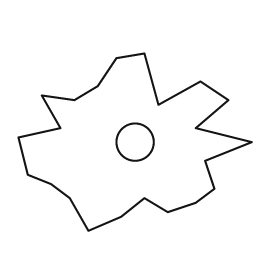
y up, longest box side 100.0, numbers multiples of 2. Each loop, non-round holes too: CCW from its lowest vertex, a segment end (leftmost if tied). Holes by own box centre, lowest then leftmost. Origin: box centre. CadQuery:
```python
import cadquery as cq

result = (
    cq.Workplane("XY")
    .moveTo(-20.0, -38.0)
    .lineTo(-6.0, -32.0)
    .lineTo(4.0, -24.0)
    .lineTo(14.0, -30.0)
    .lineTo(26.0, -26.0)
    .lineTo(34.0, -20.0)
    .lineTo(30.0, -8.0)
    .lineTo(50.0, 0.0)
    .lineTo(26.0, 6.0)
    .lineTo(40.0, 18.0)
    .lineTo(28.0, 26.0)
    .lineTo(10.0, 16.0)
    .lineTo(4.0, 38.0)
    .lineTo(-8.0, 36.0)
    .lineTo(-16.0, 24.0)
    .lineTo(-26.0, 18.0)
    .lineTo(-40.0, 20.0)
    .lineTo(-32.0, 6.0)
    .lineTo(-50.0, 2.0)
    .lineTo(-46.0, -14.0)
    .lineTo(-36.0, -18.0)
    .lineTo(-28.0, -24.0)
    .close()
    .moveTo(0.0, 0.0)
    .circle(8.0)
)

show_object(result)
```